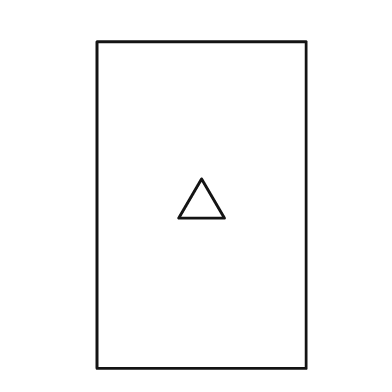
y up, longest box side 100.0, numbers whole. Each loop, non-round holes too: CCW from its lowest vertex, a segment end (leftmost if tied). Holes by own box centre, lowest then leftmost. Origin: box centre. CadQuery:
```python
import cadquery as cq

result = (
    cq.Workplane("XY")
    .moveTo(-32.0, -50.0)
    .lineTo(32.0, -50.0)
    .lineTo(32.0, 50.0)
    .lineTo(-32.0, 50.0)
    .close()
    .moveTo(-7.0, -4.0)
    .lineTo(7.0, -4.0)
    .lineTo(0.0, 8.0)
    .close()
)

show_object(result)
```